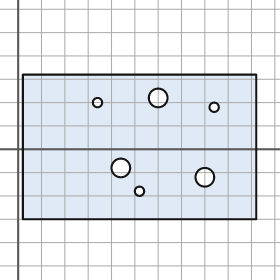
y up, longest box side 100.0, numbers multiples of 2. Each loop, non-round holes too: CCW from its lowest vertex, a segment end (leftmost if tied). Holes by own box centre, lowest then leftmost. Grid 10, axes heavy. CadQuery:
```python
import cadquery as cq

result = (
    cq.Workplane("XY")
    .moveTo(2.0, -30.0)
    .lineTo(102.0, -30.0)
    .lineTo(102.0, 32.0)
    .lineTo(2.0, 32.0)
    .close()
    .moveTo(52.0, -18.0)
    .circle(2.0)
    .moveTo(80.0, -12.0)
    .circle(4.0)
    .moveTo(44.0, -8.0)
    .circle(4.0)
    .moveTo(84.0, 18.0)
    .circle(2.0)
    .moveTo(34.0, 20.0)
    .circle(2.0)
    .moveTo(60.0, 22.0)
    .circle(4.0)
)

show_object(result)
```